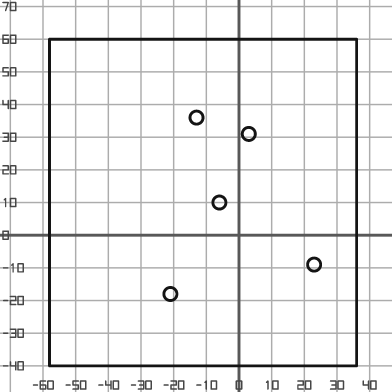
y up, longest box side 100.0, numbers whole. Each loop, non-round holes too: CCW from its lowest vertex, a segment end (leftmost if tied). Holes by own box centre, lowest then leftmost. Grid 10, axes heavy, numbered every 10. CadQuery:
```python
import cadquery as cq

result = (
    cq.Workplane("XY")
    .moveTo(-58.0, -40.0)
    .lineTo(36.0, -40.0)
    .lineTo(36.0, 60.0)
    .lineTo(-58.0, 60.0)
    .close()
    .moveTo(-21.0, -18.0)
    .circle(2.0)
    .moveTo(23.0, -9.0)
    .circle(2.0)
    .moveTo(-6.0, 10.0)
    .circle(2.0)
    .moveTo(3.0, 31.0)
    .circle(2.0)
    .moveTo(-13.0, 36.0)
    .circle(2.0)
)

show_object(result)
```